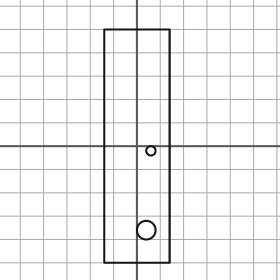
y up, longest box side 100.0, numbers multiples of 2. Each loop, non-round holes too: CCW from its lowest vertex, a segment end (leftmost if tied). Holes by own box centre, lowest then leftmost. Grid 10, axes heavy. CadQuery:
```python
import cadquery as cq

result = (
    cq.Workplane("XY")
    .moveTo(-14.0, -50.0)
    .lineTo(14.0, -50.0)
    .lineTo(14.0, 50.0)
    .lineTo(-14.0, 50.0)
    .close()
    .moveTo(4.0, -36.0)
    .circle(4.0)
    .moveTo(6.0, -2.0)
    .circle(2.0)
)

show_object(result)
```